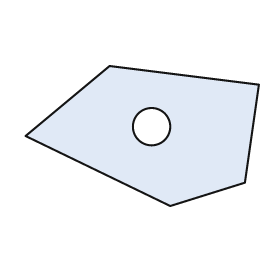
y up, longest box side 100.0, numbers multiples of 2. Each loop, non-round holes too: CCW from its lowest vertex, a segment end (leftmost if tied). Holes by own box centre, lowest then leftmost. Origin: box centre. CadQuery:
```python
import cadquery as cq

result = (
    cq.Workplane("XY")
    .moveTo(12.0, -30.0)
    .lineTo(44.0, -20.0)
    .lineTo(50.0, 22.0)
    .lineTo(-14.0, 30.0)
    .lineTo(-50.0, 0.0)
    .close()
    .moveTo(4.0, 4.0)
    .circle(8.0)
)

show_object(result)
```